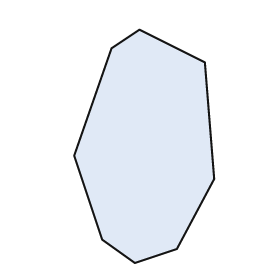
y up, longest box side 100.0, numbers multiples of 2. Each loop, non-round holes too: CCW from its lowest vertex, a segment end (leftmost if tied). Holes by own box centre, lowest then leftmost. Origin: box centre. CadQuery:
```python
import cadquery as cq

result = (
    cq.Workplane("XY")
    .moveTo(-4.0, -50.0)
    .lineTo(14.0, -44.0)
    .lineTo(30.0, -14.0)
    .lineTo(26.0, 36.0)
    .lineTo(-2.0, 50.0)
    .lineTo(-14.0, 42.0)
    .lineTo(-30.0, -4.0)
    .lineTo(-18.0, -40.0)
    .close()
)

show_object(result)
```